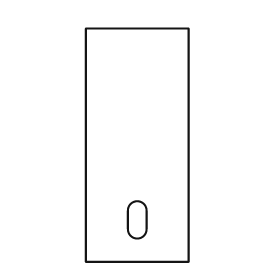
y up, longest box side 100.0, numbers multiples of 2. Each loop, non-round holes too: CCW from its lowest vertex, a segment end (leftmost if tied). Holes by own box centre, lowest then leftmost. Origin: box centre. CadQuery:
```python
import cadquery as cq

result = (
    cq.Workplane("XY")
    .moveTo(-22.0, -50.0)
    .lineTo(22.0, -50.0)
    .lineTo(22.0, 50.0)
    .lineTo(-22.0, 50.0)
    .close()
    .moveTo(-4.0, -36.0)
    .threePointArc((0.0, -40.0), (4.0, -36.0))
    .lineTo(4.0, -28.0)
    .threePointArc((0.0, -24.0), (-4.0, -28.0))
    .close()
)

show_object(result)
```